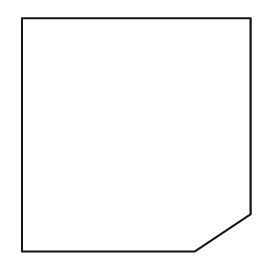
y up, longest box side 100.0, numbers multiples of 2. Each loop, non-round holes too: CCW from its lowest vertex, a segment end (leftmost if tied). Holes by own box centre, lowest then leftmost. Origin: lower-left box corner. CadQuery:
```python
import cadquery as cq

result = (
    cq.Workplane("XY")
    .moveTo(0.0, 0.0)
    .lineTo(74.0, 0.0)
    .lineTo(98.0, 16.0)
    .lineTo(98.0, 100.0)
    .lineTo(0.0, 100.0)
    .close()
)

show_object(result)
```